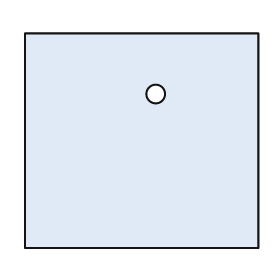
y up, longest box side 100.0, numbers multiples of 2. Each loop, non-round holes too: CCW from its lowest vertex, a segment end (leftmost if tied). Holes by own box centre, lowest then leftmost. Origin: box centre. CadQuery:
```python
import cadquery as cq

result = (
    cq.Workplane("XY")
    .moveTo(-50.0, -46.0)
    .lineTo(50.0, -46.0)
    .lineTo(50.0, 46.0)
    .lineTo(-50.0, 46.0)
    .close()
    .moveTo(6.0, 20.0)
    .circle(4.0)
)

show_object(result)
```